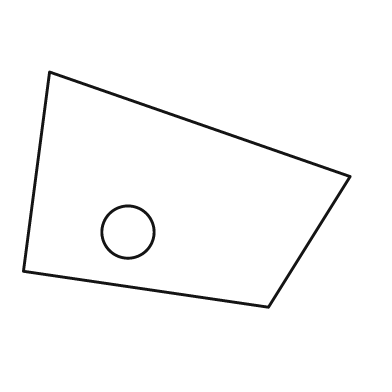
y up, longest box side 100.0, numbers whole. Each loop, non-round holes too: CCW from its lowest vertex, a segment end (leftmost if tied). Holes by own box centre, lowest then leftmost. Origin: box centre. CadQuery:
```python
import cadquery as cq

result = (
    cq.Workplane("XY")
    .moveTo(25.0, -36.0)
    .lineTo(50.0, 4.0)
    .lineTo(-42.0, 36.0)
    .lineTo(-50.0, -25.0)
    .close()
    .moveTo(-18.0, -13.0)
    .circle(8.0)
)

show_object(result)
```